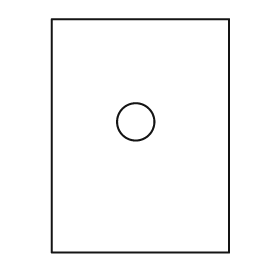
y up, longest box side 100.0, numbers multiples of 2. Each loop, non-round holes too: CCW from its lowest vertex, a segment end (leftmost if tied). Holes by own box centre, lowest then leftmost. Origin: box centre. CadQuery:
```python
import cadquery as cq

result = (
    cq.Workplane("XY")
    .moveTo(-38.0, -50.0)
    .lineTo(38.0, -50.0)
    .lineTo(38.0, 50.0)
    .lineTo(-38.0, 50.0)
    .close()
    .moveTo(-2.0, 6.0)
    .circle(8.0)
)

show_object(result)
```